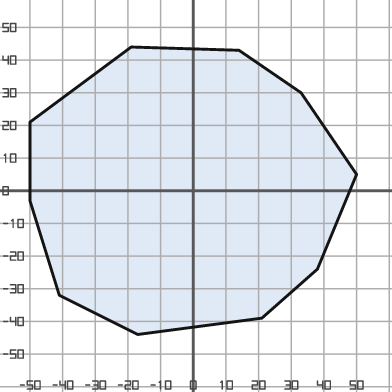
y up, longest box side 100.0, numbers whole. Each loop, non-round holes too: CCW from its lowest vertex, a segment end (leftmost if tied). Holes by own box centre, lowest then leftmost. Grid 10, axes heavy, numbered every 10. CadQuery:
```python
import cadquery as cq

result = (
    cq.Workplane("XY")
    .moveTo(-17.0, -44.0)
    .lineTo(21.0, -39.0)
    .lineTo(38.0, -24.0)
    .lineTo(50.0, 5.0)
    .lineTo(33.0, 30.0)
    .lineTo(14.0, 43.0)
    .lineTo(-19.0, 44.0)
    .lineTo(-50.0, 21.0)
    .lineTo(-50.0, -3.0)
    .lineTo(-41.0, -32.0)
    .close()
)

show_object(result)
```